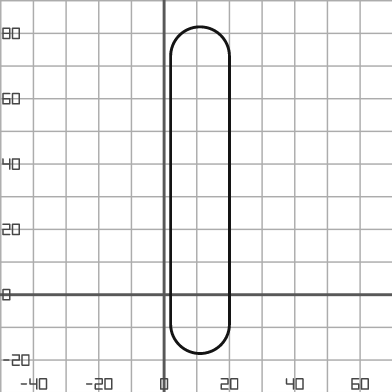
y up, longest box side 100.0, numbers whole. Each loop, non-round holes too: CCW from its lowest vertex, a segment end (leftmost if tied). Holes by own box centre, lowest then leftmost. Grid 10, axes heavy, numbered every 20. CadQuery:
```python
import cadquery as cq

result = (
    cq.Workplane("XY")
    .moveTo(2.0, -9.0)
    .threePointArc((11.0, -18.0), (20.0, -9.0))
    .lineTo(20.0, 73.0)
    .threePointArc((11.0, 82.0), (2.0, 73.0))
    .close()
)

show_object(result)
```